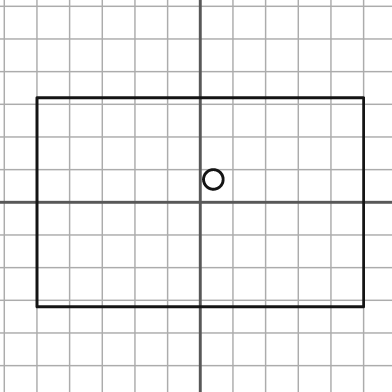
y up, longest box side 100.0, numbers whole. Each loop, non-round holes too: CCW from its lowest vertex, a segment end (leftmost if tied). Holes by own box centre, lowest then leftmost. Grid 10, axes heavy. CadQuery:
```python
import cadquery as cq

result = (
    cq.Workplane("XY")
    .moveTo(-50.0, -32.0)
    .lineTo(50.0, -32.0)
    .lineTo(50.0, 32.0)
    .lineTo(-50.0, 32.0)
    .close()
    .moveTo(4.0, 7.0)
    .circle(3.0)
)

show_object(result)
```